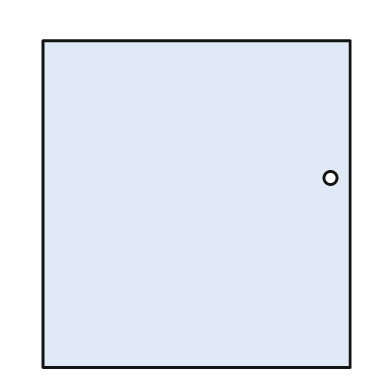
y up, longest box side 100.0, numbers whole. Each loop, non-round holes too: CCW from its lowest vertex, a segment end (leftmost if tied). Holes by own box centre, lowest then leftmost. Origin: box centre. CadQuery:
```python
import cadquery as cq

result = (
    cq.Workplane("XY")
    .moveTo(-47.0, -50.0)
    .lineTo(47.0, -50.0)
    .lineTo(47.0, 50.0)
    .lineTo(-47.0, 50.0)
    .close()
    .moveTo(41.0, 8.0)
    .circle(2.0)
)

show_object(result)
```